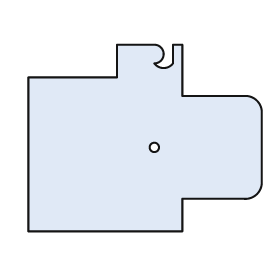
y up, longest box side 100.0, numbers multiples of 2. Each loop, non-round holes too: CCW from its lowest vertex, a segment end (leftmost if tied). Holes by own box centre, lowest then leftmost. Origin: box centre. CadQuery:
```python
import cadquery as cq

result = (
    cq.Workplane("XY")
    .moveTo(-50.0, -40.0)
    .lineTo(16.0, -40.0)
    .lineTo(16.0, -26.0)
    .lineTo(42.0, -26.0)
    .threePointArc((48.0, -24.0), (50.0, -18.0))
    .lineTo(50.0, 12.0)
    .threePointArc((48.0, 16.0), (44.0, 18.0))
    .lineTo(16.0, 18.0)
    .lineTo(16.0, 40.0)
    .lineTo(12.0, 40.0)
    .lineTo(12.0, 32.0)
    .threePointArc((8.0, 30.0), (4.0, 32.0))
    .threePointArc((8.0, 36.0), (4.0, 40.0))
    .lineTo(-12.0, 40.0)
    .lineTo(-12.0, 26.0)
    .lineTo(-50.0, 26.0)
    .close()
    .moveTo(4.0, -4.0)
    .circle(2.0)
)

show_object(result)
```